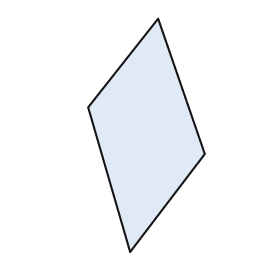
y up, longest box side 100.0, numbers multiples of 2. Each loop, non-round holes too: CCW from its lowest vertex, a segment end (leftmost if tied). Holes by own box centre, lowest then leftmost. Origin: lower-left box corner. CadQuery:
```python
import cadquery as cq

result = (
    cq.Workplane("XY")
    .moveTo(18.0, 0.0)
    .lineTo(50.0, 42.0)
    .lineTo(30.0, 100.0)
    .lineTo(0.0, 62.0)
    .close()
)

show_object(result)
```